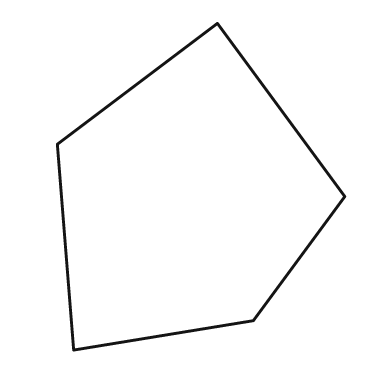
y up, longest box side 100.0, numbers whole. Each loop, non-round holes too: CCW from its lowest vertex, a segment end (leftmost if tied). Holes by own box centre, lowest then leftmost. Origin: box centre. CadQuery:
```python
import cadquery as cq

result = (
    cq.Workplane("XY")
    .moveTo(-39.0, -50.0)
    .lineTo(16.0, -41.0)
    .lineTo(44.0, -3.0)
    .lineTo(5.0, 50.0)
    .lineTo(-44.0, 13.0)
    .close()
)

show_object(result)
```